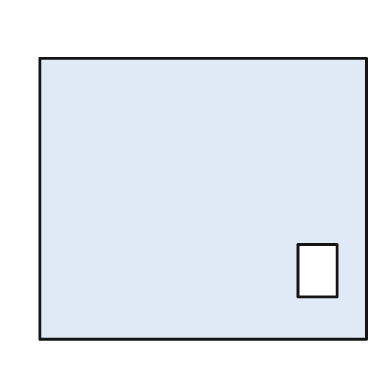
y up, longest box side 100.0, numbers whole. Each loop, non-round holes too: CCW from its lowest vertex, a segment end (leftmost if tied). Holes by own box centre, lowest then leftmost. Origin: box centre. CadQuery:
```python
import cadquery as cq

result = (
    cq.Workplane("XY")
    .moveTo(-50.0, -43.0)
    .lineTo(50.0, -43.0)
    .lineTo(50.0, 43.0)
    .lineTo(-50.0, 43.0)
    .close()
    .moveTo(29.0, -30.0)
    .lineTo(41.0, -30.0)
    .lineTo(41.0, -14.0)
    .lineTo(29.0, -14.0)
    .close()
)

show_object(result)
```